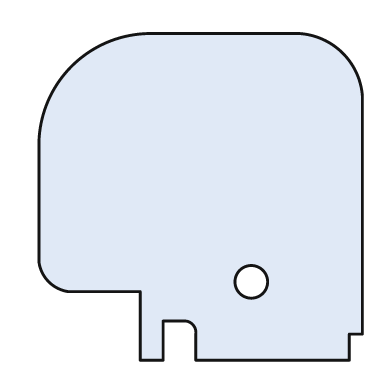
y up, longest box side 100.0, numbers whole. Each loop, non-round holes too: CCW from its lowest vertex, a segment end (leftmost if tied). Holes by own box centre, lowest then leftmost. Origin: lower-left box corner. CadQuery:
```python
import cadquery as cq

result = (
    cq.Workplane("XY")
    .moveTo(31.0, 0.0)
    .lineTo(38.0, 0.0)
    .lineTo(38.0, 12.0)
    .lineTo(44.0, 12.0)
    .threePointArc((47.0, 11.0), (48.0, 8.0))
    .lineTo(48.0, 0.0)
    .lineTo(95.0, 0.0)
    .lineTo(95.0, 8.0)
    .lineTo(99.0, 8.0)
    .lineTo(99.0, 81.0)
    .threePointArc((93.0, 94.0), (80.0, 100.0))
    .lineTo(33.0, 100.0)
    .threePointArc((10.0, 90.0), (0.0, 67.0))
    .lineTo(0.0, 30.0)
    .threePointArc((3.0, 24.0), (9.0, 21.0))
    .lineTo(31.0, 21.0)
    .close()
    .moveTo(65.0, 24.0)
    .circle(5.0)
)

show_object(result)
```